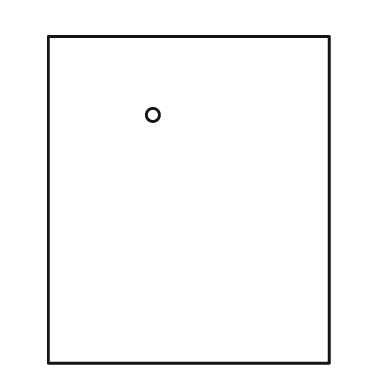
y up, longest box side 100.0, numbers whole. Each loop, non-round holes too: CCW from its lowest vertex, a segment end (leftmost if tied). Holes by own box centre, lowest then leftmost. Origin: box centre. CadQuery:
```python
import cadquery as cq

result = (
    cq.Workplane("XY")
    .moveTo(-43.0, -50.0)
    .lineTo(43.0, -50.0)
    .lineTo(43.0, 50.0)
    .lineTo(-43.0, 50.0)
    .close()
    .moveTo(-11.0, 26.0)
    .circle(2.0)
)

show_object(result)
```